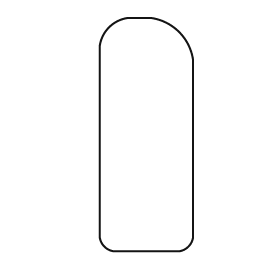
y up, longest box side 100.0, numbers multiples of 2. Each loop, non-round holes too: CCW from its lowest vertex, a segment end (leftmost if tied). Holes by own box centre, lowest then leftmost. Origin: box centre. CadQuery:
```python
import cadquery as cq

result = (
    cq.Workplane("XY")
    .moveTo(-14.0, -50.0)
    .lineTo(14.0, -50.0)
    .threePointArc((18.0, -48.0), (20.0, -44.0))
    .lineTo(20.0, 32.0)
    .threePointArc((14.0, 44.0), (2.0, 50.0))
    .lineTo(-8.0, 50.0)
    .threePointArc((-16.0, 46.0), (-20.0, 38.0))
    .lineTo(-20.0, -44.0)
    .threePointArc((-18.0, -48.0), (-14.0, -50.0))
    .close()
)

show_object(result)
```